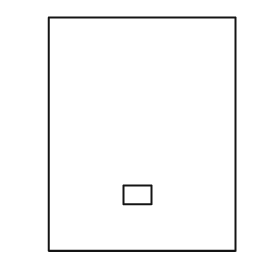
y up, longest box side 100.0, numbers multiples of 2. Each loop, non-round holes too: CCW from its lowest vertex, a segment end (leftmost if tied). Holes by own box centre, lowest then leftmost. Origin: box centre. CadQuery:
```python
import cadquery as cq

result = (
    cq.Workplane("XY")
    .moveTo(-40.0, -50.0)
    .lineTo(40.0, -50.0)
    .lineTo(40.0, 50.0)
    .lineTo(-40.0, 50.0)
    .close()
    .moveTo(-8.0, -30.0)
    .lineTo(4.0, -30.0)
    .lineTo(4.0, -22.0)
    .lineTo(-8.0, -22.0)
    .close()
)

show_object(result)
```